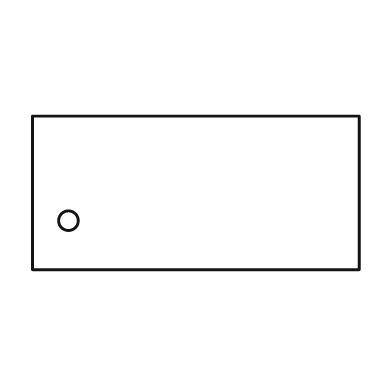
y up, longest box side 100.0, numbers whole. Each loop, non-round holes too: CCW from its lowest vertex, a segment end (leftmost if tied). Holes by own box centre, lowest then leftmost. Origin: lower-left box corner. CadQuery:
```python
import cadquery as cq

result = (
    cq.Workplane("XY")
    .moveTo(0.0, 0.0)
    .lineTo(100.0, 0.0)
    .lineTo(100.0, 47.0)
    .lineTo(0.0, 47.0)
    .close()
    .moveTo(11.0, 15.0)
    .circle(3.0)
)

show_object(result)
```